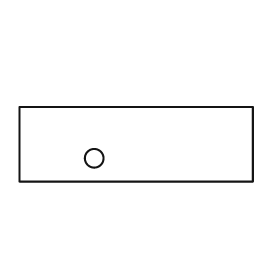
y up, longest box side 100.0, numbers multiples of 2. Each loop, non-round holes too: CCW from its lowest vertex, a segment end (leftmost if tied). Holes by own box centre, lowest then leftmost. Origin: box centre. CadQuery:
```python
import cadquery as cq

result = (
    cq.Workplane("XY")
    .moveTo(-50.0, -16.0)
    .lineTo(50.0, -16.0)
    .lineTo(50.0, 16.0)
    .lineTo(-50.0, 16.0)
    .close()
    .moveTo(-18.0, -6.0)
    .circle(4.0)
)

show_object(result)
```